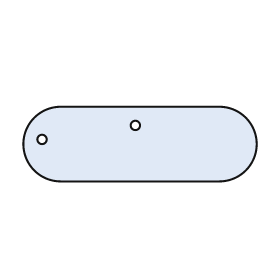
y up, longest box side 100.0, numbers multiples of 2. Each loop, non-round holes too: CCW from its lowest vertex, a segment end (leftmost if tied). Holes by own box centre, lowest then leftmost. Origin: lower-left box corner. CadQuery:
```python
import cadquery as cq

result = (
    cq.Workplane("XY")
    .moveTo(16.0, 0.0)
    .lineTo(84.0, 0.0)
    .threePointArc((100.0, 16.0), (84.0, 32.0))
    .lineTo(16.0, 32.0)
    .threePointArc((0.0, 16.0), (16.0, 0.0))
    .close()
    .moveTo(8.0, 18.0)
    .circle(2.0)
    .moveTo(48.0, 24.0)
    .circle(2.0)
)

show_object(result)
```